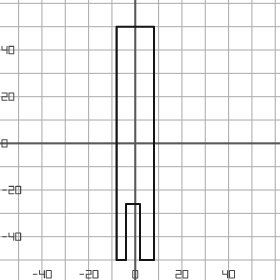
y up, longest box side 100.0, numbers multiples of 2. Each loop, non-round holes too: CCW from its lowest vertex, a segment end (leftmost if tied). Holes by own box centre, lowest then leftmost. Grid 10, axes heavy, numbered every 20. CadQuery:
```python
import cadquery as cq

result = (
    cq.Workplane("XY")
    .moveTo(-8.0, -50.0)
    .lineTo(-4.0, -50.0)
    .lineTo(-4.0, -26.0)
    .lineTo(2.0, -26.0)
    .lineTo(2.0, -50.0)
    .lineTo(8.0, -50.0)
    .lineTo(8.0, 50.0)
    .lineTo(-8.0, 50.0)
    .close()
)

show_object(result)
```